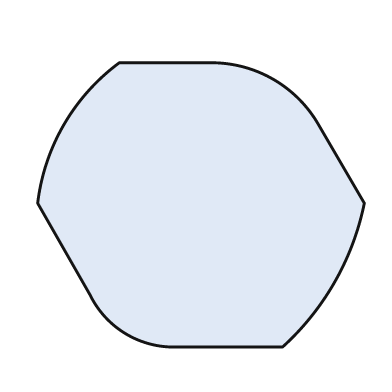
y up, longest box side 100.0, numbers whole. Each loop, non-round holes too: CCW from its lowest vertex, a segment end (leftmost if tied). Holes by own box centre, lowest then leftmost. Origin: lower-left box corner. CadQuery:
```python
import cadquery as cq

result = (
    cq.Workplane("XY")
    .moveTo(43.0, 0.0)
    .lineTo(75.0, 0.0)
    .threePointArc((91.0, 20.0), (100.0, 44.0))
    .lineTo(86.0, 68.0)
    .threePointArc((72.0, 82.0), (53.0, 87.0))
    .lineTo(25.0, 87.0)
    .threePointArc((8.0, 68.0), (0.0, 44.0))
    .lineTo(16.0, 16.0)
    .threePointArc((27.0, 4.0), (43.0, 0.0))
    .close()
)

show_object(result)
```